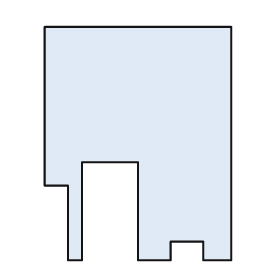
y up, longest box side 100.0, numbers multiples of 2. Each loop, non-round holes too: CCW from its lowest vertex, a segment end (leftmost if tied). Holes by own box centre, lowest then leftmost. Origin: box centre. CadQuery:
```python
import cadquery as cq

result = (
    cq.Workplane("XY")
    .moveTo(-30.0, -50.0)
    .lineTo(-24.0, -50.0)
    .lineTo(-24.0, -8.0)
    .lineTo(0.0, -8.0)
    .lineTo(0.0, -50.0)
    .lineTo(14.0, -50.0)
    .lineTo(14.0, -42.0)
    .lineTo(28.0, -42.0)
    .lineTo(28.0, -50.0)
    .lineTo(40.0, -50.0)
    .lineTo(40.0, 50.0)
    .lineTo(-40.0, 50.0)
    .lineTo(-40.0, -18.0)
    .lineTo(-30.0, -18.0)
    .close()
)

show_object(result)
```